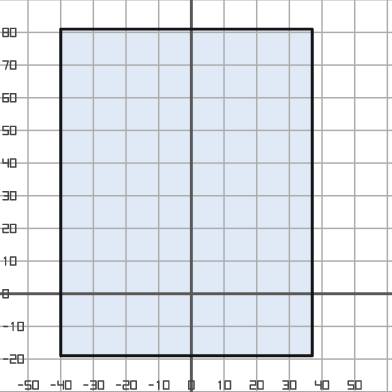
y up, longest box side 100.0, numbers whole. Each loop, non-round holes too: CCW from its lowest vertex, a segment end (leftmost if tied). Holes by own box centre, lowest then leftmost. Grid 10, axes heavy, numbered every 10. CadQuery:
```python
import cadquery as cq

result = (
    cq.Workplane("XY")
    .moveTo(-40.0, -19.0)
    .lineTo(37.0, -19.0)
    .lineTo(37.0, 81.0)
    .lineTo(-40.0, 81.0)
    .close()
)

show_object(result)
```